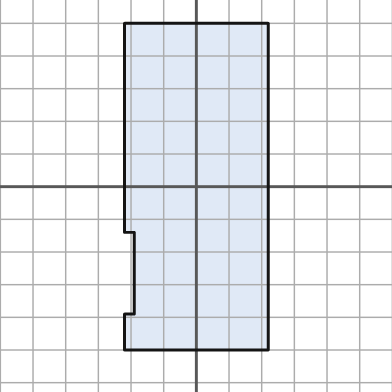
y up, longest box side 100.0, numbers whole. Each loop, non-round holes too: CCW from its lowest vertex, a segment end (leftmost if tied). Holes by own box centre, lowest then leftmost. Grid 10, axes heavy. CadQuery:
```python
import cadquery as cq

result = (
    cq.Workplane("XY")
    .moveTo(-22.0, -50.0)
    .lineTo(22.0, -50.0)
    .lineTo(22.0, 50.0)
    .lineTo(-22.0, 50.0)
    .lineTo(-22.0, -14.0)
    .lineTo(-19.0, -14.0)
    .lineTo(-19.0, -39.0)
    .lineTo(-22.0, -39.0)
    .close()
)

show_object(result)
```